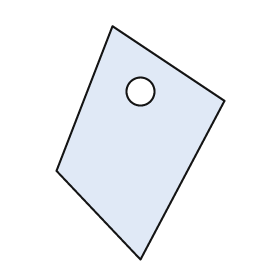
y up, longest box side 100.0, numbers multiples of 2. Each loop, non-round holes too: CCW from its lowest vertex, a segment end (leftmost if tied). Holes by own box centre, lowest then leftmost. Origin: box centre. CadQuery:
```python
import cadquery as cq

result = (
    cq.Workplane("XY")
    .moveTo(0.0, -50.0)
    .lineTo(36.0, 18.0)
    .lineTo(-12.0, 50.0)
    .lineTo(-36.0, -12.0)
    .close()
    .moveTo(0.0, 22.0)
    .circle(6.0)
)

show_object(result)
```